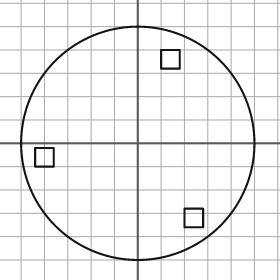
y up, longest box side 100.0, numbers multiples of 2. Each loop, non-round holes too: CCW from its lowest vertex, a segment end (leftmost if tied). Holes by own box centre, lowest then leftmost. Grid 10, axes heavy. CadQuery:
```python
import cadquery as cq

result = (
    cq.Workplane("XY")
    .moveTo(0.0, 0.0)
    .circle(50.0)
    .moveTo(20.0, -36.0)
    .lineTo(28.0, -36.0)
    .lineTo(28.0, -28.0)
    .lineTo(20.0, -28.0)
    .close()
    .moveTo(-44.0, -10.0)
    .lineTo(-36.0, -10.0)
    .lineTo(-36.0, -2.0)
    .lineTo(-44.0, -2.0)
    .close()
    .moveTo(10.0, 32.0)
    .lineTo(18.0, 32.0)
    .lineTo(18.0, 40.0)
    .lineTo(10.0, 40.0)
    .close()
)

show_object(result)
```